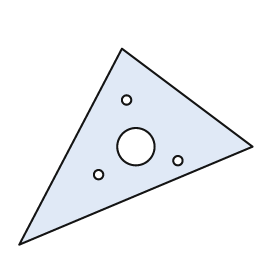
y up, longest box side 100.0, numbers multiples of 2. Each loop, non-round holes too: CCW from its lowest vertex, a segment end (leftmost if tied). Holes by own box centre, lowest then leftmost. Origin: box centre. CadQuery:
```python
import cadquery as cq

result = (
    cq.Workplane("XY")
    .moveTo(-50.0, -42.0)
    .lineTo(50.0, 0.0)
    .lineTo(-6.0, 42.0)
    .close()
    .moveTo(-16.0, -12.0)
    .circle(2.0)
    .moveTo(18.0, -6.0)
    .circle(2.0)
    .moveTo(0.0, 0.0)
    .circle(8.0)
    .moveTo(-4.0, 20.0)
    .circle(2.0)
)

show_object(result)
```